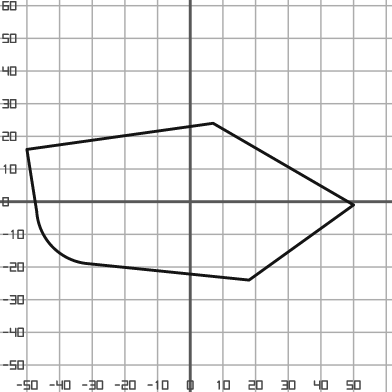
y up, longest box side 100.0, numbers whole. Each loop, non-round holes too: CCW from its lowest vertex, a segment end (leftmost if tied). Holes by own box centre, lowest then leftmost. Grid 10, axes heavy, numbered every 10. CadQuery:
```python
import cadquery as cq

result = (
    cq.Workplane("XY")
    .moveTo(18.0, -24.0)
    .lineTo(50.0, -1.0)
    .lineTo(7.0, 24.0)
    .lineTo(-50.0, 16.0)
    .lineTo(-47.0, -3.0)
    .threePointArc((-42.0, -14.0), (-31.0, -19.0))
    .close()
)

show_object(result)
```